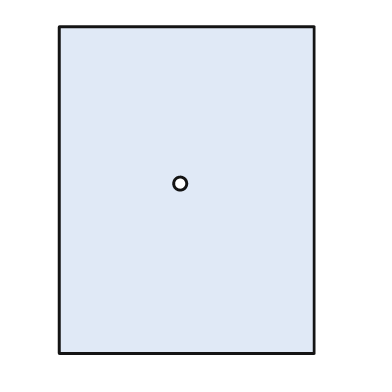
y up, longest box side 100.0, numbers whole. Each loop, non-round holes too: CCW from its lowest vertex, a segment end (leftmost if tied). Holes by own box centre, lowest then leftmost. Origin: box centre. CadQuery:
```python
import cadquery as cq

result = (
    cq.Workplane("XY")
    .moveTo(-39.0, -50.0)
    .lineTo(39.0, -50.0)
    .lineTo(39.0, 50.0)
    .lineTo(-39.0, 50.0)
    .close()
    .moveTo(-2.0, 2.0)
    .circle(2.0)
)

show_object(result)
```